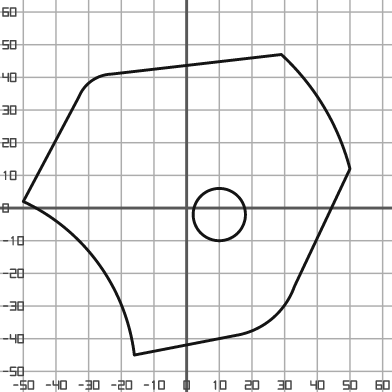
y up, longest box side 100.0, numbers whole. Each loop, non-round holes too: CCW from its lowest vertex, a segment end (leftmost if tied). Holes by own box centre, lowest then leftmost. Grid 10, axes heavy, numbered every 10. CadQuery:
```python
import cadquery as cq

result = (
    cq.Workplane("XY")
    .moveTo(-16.0, -45.0)
    .lineTo(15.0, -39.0)
    .threePointArc((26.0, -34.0), (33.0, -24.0))
    .lineTo(50.0, 12.0)
    .threePointArc((42.0, 31.0), (29.0, 47.0))
    .lineTo(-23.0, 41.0)
    .threePointArc((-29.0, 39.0), (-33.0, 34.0))
    .lineTo(-50.0, 2.0)
    .threePointArc((-27.0, -17.0), (-16.0, -45.0))
    .close()
    .moveTo(10.0, -2.0)
    .circle(8.0)
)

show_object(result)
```